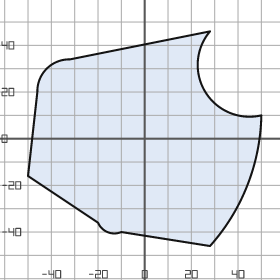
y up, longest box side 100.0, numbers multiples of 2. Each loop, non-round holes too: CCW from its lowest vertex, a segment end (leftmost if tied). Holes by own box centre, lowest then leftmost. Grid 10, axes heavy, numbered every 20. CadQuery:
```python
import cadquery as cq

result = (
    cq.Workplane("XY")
    .moveTo(28.0, -46.0)
    .threePointArc((44.0, -20.0), (50.0, 10.0))
    .threePointArc((26.0, 20.0), (28.0, 46.0))
    .lineTo(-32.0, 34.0)
    .threePointArc((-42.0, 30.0), (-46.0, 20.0))
    .lineTo(-50.0, -16.0)
    .lineTo(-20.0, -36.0)
    .threePointArc((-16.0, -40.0), (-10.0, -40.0))
    .close()
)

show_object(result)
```